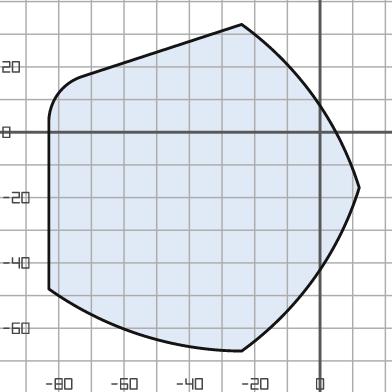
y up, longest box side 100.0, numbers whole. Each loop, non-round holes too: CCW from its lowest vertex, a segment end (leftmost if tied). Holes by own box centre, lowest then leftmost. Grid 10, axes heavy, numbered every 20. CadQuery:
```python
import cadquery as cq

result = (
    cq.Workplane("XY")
    .moveTo(-24.0, -67.0)
    .threePointArc((-2.0, -45.0), (12.0, -17.0))
    .threePointArc((-2.0, 11.0), (-24.0, 33.0))
    .lineTo(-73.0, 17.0)
    .threePointArc((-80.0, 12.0), (-83.0, 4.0))
    .lineTo(-83.0, -48.0)
    .threePointArc((-55.0, -62.0), (-24.0, -67.0))
    .close()
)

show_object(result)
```